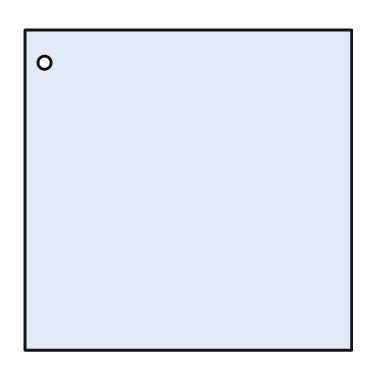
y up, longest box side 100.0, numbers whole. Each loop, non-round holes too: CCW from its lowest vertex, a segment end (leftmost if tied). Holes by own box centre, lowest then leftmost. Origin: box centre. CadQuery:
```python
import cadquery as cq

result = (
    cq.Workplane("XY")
    .moveTo(-50.0, -49.0)
    .lineTo(50.0, -49.0)
    .lineTo(50.0, 49.0)
    .lineTo(-50.0, 49.0)
    .close()
    .moveTo(-44.0, 39.0)
    .circle(2.0)
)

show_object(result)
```